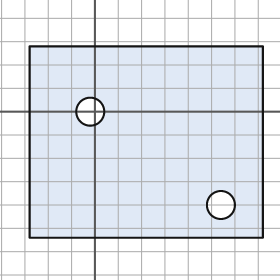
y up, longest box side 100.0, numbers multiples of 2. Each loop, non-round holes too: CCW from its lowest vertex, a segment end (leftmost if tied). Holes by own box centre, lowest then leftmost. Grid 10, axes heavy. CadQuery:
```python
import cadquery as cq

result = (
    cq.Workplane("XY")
    .moveTo(-28.0, -54.0)
    .lineTo(72.0, -54.0)
    .lineTo(72.0, 28.0)
    .lineTo(-28.0, 28.0)
    .close()
    .moveTo(54.0, -40.0)
    .circle(6.0)
    .moveTo(-2.0, 0.0)
    .circle(6.0)
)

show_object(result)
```